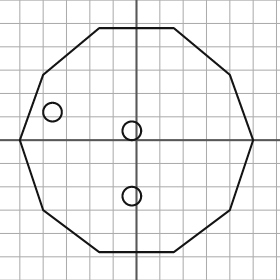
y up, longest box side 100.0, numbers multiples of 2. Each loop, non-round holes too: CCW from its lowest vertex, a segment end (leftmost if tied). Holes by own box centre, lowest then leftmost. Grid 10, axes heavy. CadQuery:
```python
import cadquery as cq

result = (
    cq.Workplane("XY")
    .moveTo(-16.0, -48.0)
    .lineTo(16.0, -48.0)
    .lineTo(40.0, -30.0)
    .lineTo(50.0, 0.0)
    .lineTo(40.0, 28.0)
    .lineTo(16.0, 48.0)
    .lineTo(-16.0, 48.0)
    .lineTo(-40.0, 28.0)
    .lineTo(-50.0, 0.0)
    .lineTo(-40.0, -30.0)
    .close()
    .moveTo(-2.0, -24.0)
    .circle(4.0)
    .moveTo(-2.0, 4.0)
    .circle(4.0)
    .moveTo(-36.0, 12.0)
    .circle(4.0)
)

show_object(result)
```